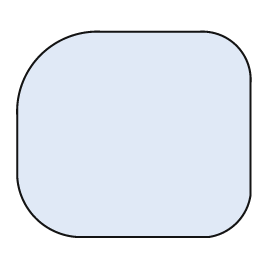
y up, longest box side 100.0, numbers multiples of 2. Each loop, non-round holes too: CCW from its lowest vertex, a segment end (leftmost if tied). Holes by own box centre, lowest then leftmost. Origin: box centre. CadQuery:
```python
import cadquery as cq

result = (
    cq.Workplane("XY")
    .moveTo(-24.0, -44.0)
    .lineTo(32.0, -44.0)
    .threePointArc((44.0, -38.0), (50.0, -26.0))
    .lineTo(50.0, 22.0)
    .threePointArc((44.0, 38.0), (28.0, 44.0))
    .lineTo(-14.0, 44.0)
    .threePointArc((-40.0, 34.0), (-50.0, 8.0))
    .lineTo(-50.0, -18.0)
    .threePointArc((-42.0, -36.0), (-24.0, -44.0))
    .close()
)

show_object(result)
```